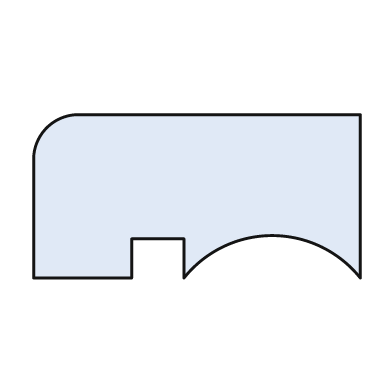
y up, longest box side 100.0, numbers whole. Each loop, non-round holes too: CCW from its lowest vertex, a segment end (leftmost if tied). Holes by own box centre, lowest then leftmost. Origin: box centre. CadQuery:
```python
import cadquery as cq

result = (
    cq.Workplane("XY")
    .moveTo(-50.0, -25.0)
    .lineTo(-20.0, -25.0)
    .lineTo(-20.0, -13.0)
    .lineTo(-4.0, -13.0)
    .lineTo(-4.0, -25.0)
    .threePointArc((23.0, -12.0), (50.0, -25.0))
    .lineTo(50.0, 25.0)
    .lineTo(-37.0, 25.0)
    .threePointArc((-46.0, 21.0), (-50.0, 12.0))
    .close()
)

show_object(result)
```